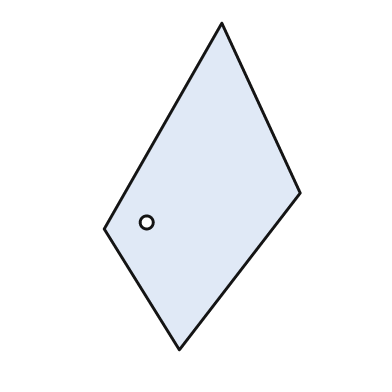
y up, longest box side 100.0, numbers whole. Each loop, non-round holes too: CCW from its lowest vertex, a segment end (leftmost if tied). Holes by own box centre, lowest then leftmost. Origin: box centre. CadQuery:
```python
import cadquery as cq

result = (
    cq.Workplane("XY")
    .moveTo(-7.0, -50.0)
    .lineTo(30.0, -2.0)
    .lineTo(6.0, 50.0)
    .lineTo(-30.0, -13.0)
    .close()
    .moveTo(-17.0, -11.0)
    .circle(2.0)
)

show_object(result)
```